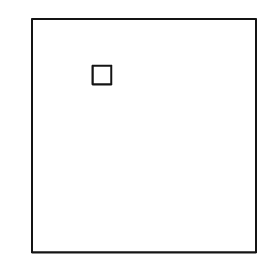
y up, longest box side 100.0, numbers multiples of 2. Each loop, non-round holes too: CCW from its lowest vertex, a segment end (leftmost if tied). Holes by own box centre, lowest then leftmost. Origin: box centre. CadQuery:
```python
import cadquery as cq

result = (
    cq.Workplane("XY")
    .moveTo(-48.0, -50.0)
    .lineTo(48.0, -50.0)
    .lineTo(48.0, 50.0)
    .lineTo(-48.0, 50.0)
    .close()
    .moveTo(-22.0, 22.0)
    .lineTo(-14.0, 22.0)
    .lineTo(-14.0, 30.0)
    .lineTo(-22.0, 30.0)
    .close()
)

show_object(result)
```